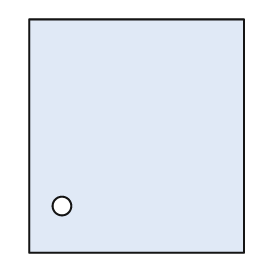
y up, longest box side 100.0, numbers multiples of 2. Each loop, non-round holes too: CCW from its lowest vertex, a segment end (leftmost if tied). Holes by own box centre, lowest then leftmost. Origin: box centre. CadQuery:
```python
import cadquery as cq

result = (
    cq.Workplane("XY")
    .moveTo(-46.0, -50.0)
    .lineTo(46.0, -50.0)
    .lineTo(46.0, 50.0)
    .lineTo(-46.0, 50.0)
    .close()
    .moveTo(-32.0, -30.0)
    .circle(4.0)
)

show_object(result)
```